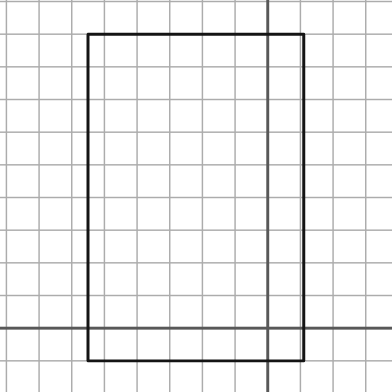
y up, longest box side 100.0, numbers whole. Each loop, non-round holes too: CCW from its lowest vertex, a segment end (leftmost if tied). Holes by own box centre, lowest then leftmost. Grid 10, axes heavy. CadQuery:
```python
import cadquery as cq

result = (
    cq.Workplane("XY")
    .moveTo(-55.0, -10.0)
    .lineTo(11.0, -10.0)
    .lineTo(11.0, 90.0)
    .lineTo(-55.0, 90.0)
    .close()
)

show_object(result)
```